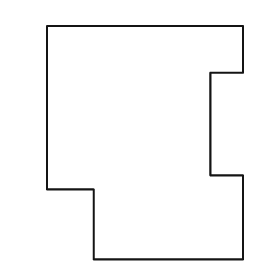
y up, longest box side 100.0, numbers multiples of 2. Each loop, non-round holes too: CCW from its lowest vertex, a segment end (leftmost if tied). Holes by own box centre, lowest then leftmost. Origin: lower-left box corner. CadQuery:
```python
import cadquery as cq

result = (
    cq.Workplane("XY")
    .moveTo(20.0, 0.0)
    .lineTo(84.0, 0.0)
    .lineTo(84.0, 36.0)
    .lineTo(70.0, 36.0)
    .lineTo(70.0, 80.0)
    .lineTo(84.0, 80.0)
    .lineTo(84.0, 100.0)
    .lineTo(0.0, 100.0)
    .lineTo(0.0, 30.0)
    .lineTo(20.0, 30.0)
    .close()
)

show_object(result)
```